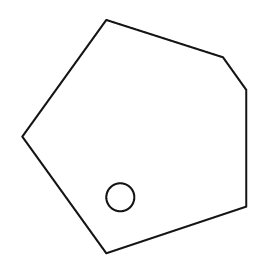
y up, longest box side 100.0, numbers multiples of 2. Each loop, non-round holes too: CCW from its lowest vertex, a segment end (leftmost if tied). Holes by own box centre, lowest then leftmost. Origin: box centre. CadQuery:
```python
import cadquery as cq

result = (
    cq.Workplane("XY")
    .moveTo(-12.0, -50.0)
    .lineTo(48.0, -30.0)
    .lineTo(48.0, 20.0)
    .lineTo(38.0, 34.0)
    .lineTo(-12.0, 50.0)
    .lineTo(-48.0, 0.0)
    .close()
    .moveTo(-6.0, -26.0)
    .circle(6.0)
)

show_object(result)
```